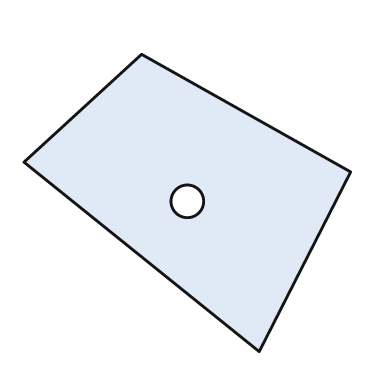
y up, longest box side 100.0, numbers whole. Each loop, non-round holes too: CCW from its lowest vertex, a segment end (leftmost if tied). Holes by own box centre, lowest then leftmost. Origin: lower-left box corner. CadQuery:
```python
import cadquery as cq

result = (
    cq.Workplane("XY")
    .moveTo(72.0, 0.0)
    .lineTo(100.0, 55.0)
    .lineTo(36.0, 91.0)
    .lineTo(0.0, 58.0)
    .close()
    .moveTo(50.0, 46.0)
    .circle(5.0)
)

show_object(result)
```